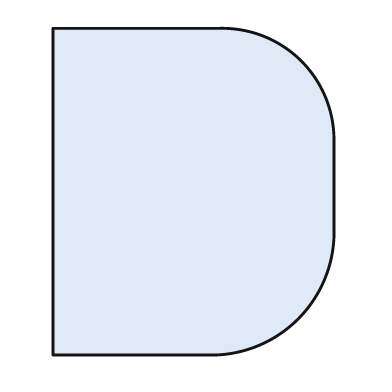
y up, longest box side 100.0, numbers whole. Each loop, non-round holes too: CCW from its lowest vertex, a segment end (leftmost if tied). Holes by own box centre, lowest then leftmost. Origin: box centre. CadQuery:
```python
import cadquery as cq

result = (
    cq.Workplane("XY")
    .moveTo(-43.0, -50.0)
    .lineTo(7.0, -50.0)
    .threePointArc((32.0, -39.0), (43.0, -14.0))
    .lineTo(43.0, 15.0)
    .threePointArc((33.0, 40.0), (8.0, 50.0))
    .lineTo(-43.0, 50.0)
    .close()
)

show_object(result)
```